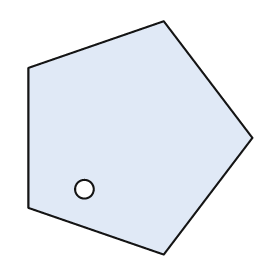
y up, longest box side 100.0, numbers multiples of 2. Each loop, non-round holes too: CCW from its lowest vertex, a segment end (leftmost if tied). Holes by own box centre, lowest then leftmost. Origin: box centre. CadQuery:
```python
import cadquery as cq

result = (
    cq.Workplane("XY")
    .moveTo(10.0, -50.0)
    .lineTo(48.0, 0.0)
    .lineTo(10.0, 50.0)
    .lineTo(-48.0, 30.0)
    .lineTo(-48.0, -30.0)
    .close()
    .moveTo(-24.0, -22.0)
    .circle(4.0)
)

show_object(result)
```